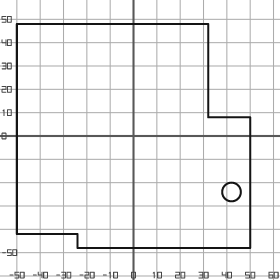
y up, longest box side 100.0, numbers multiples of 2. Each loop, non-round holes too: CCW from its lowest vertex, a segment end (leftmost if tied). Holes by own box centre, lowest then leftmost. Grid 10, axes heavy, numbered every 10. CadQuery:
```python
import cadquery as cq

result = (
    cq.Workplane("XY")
    .moveTo(-24.0, -48.0)
    .lineTo(50.0, -48.0)
    .lineTo(50.0, 8.0)
    .lineTo(32.0, 8.0)
    .lineTo(32.0, 48.0)
    .lineTo(-50.0, 48.0)
    .lineTo(-50.0, -42.0)
    .lineTo(-24.0, -42.0)
    .close()
    .moveTo(42.0, -24.0)
    .circle(4.0)
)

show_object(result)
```